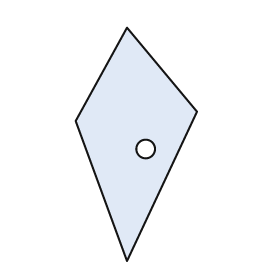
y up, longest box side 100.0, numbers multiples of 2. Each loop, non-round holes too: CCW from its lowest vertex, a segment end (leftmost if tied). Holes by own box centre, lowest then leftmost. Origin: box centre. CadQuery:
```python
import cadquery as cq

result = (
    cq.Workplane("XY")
    .moveTo(-4.0, -50.0)
    .lineTo(26.0, 14.0)
    .lineTo(-4.0, 50.0)
    .lineTo(-26.0, 10.0)
    .close()
    .moveTo(4.0, -2.0)
    .circle(4.0)
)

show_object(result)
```